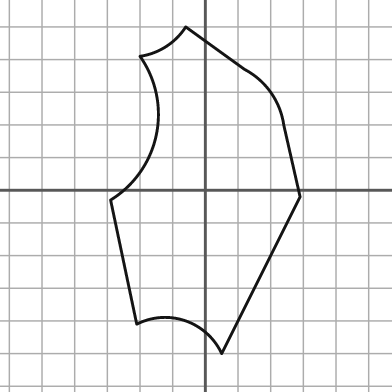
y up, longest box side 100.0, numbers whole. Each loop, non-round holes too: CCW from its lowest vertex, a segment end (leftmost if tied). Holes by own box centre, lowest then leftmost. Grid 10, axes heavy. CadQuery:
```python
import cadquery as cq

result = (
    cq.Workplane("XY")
    .moveTo(5.0, -50.0)
    .lineTo(29.0, -2.0)
    .lineTo(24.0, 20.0)
    .threePointArc((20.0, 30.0), (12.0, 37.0))
    .lineTo(-6.0, 50.0)
    .threePointArc((-12.0, 44.0), (-20.0, 41.0))
    .threePointArc((-15.0, 17.0), (-29.0, -3.0))
    .lineTo(-21.0, -41.0)
    .threePointArc((-6.0, -40.0), (5.0, -50.0))
    .close()
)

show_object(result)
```